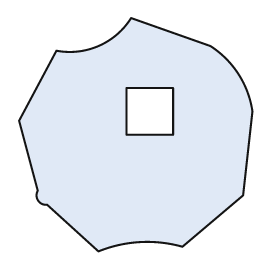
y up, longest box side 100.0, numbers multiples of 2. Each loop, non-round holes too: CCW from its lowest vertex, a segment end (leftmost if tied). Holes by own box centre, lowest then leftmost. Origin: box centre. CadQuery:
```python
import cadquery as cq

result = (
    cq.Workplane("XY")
    .moveTo(-16.0, -50.0)
    .threePointArc((2.0, -46.0), (20.0, -48.0))
    .lineTo(46.0, -26.0)
    .lineTo(50.0, 10.0)
    .threePointArc((44.0, 26.0), (32.0, 38.0))
    .lineTo(-2.0, 50.0)
    .threePointArc((-16.0, 38.0), (-34.0, 36.0))
    .lineTo(-50.0, 6.0)
    .lineTo(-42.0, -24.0)
    .threePointArc((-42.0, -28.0), (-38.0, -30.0))
    .close()
    .moveTo(-4.0, 0.0)
    .lineTo(16.0, 0.0)
    .lineTo(16.0, 20.0)
    .lineTo(-4.0, 20.0)
    .close()
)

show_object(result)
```